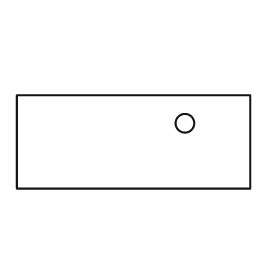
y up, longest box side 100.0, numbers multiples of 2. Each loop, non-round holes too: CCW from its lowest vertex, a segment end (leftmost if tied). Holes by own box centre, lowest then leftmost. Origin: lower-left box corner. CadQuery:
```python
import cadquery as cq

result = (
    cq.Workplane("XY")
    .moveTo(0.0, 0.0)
    .lineTo(100.0, 0.0)
    .lineTo(100.0, 40.0)
    .lineTo(0.0, 40.0)
    .close()
    .moveTo(72.0, 28.0)
    .circle(4.0)
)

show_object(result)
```